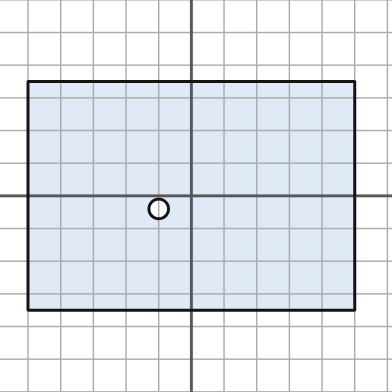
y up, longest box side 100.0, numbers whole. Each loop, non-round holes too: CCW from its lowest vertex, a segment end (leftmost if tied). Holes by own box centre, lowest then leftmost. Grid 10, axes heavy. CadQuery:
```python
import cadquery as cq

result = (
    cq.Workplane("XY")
    .moveTo(-50.0, -35.0)
    .lineTo(50.0, -35.0)
    .lineTo(50.0, 35.0)
    .lineTo(-50.0, 35.0)
    .close()
    .moveTo(-10.0, -4.0)
    .circle(3.0)
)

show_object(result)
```